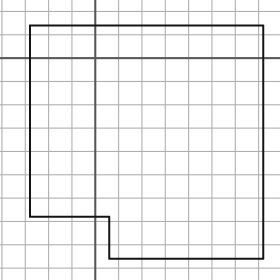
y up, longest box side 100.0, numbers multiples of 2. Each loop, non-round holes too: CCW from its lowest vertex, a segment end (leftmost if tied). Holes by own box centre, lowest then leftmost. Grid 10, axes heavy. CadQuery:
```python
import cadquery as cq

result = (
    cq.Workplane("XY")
    .moveTo(6.0, -86.0)
    .lineTo(72.0, -86.0)
    .lineTo(72.0, 14.0)
    .lineTo(-28.0, 14.0)
    .lineTo(-28.0, -68.0)
    .lineTo(6.0, -68.0)
    .close()
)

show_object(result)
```